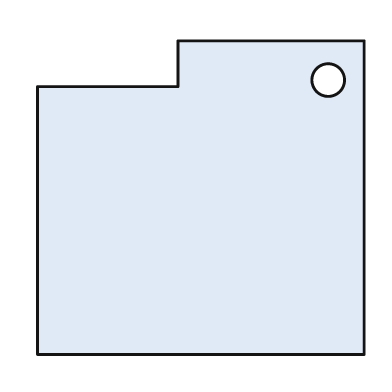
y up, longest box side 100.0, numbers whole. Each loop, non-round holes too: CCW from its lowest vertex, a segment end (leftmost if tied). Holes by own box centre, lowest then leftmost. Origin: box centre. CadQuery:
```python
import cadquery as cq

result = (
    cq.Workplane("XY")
    .moveTo(-50.0, -48.0)
    .lineTo(50.0, -48.0)
    .lineTo(50.0, 48.0)
    .lineTo(-7.0, 48.0)
    .lineTo(-7.0, 34.0)
    .lineTo(-50.0, 34.0)
    .close()
    .moveTo(39.0, 36.0)
    .circle(5.0)
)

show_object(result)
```